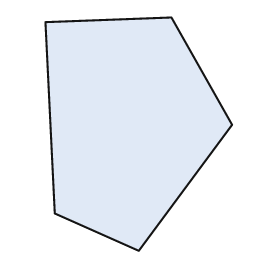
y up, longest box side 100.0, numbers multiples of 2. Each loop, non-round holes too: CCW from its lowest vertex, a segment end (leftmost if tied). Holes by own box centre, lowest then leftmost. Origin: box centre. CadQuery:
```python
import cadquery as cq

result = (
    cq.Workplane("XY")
    .moveTo(0.0, -50.0)
    .lineTo(40.0, 4.0)
    .lineTo(14.0, 50.0)
    .lineTo(-40.0, 48.0)
    .lineTo(-36.0, -34.0)
    .close()
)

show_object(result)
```